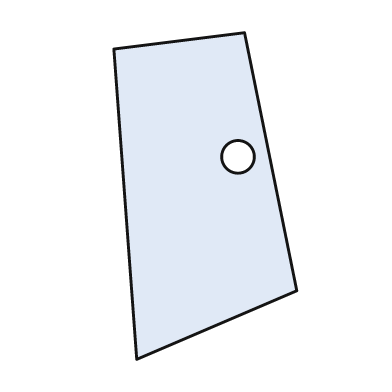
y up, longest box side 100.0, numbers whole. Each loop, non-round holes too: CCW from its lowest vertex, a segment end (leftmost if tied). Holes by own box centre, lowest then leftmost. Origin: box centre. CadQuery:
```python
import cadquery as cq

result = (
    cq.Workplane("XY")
    .moveTo(-21.0, -50.0)
    .lineTo(28.0, -29.0)
    .lineTo(12.0, 50.0)
    .lineTo(-28.0, 45.0)
    .close()
    .moveTo(10.0, 12.0)
    .circle(5.0)
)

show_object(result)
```